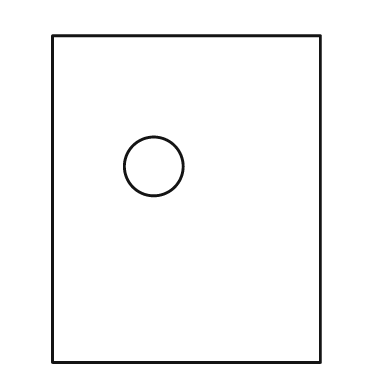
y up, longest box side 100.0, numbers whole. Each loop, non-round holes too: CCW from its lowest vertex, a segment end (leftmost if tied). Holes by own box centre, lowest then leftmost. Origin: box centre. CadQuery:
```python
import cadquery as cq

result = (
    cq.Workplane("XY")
    .moveTo(-41.0, -50.0)
    .lineTo(41.0, -50.0)
    .lineTo(41.0, 50.0)
    .lineTo(-41.0, 50.0)
    .close()
    .moveTo(-10.0, 10.0)
    .circle(9.0)
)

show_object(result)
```